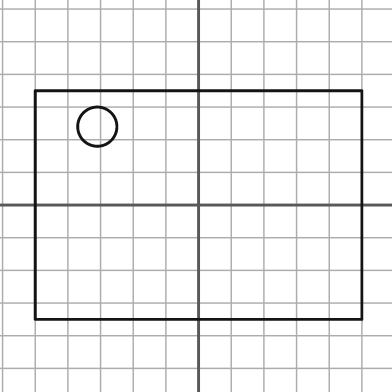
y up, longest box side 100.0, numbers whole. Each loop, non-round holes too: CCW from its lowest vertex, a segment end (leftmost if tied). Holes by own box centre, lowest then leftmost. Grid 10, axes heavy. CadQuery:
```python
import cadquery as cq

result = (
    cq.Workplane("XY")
    .moveTo(-50.0, -35.0)
    .lineTo(50.0, -35.0)
    .lineTo(50.0, 35.0)
    .lineTo(-50.0, 35.0)
    .close()
    .moveTo(-31.0, 24.0)
    .circle(6.0)
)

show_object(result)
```